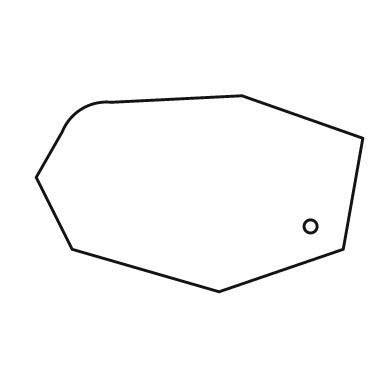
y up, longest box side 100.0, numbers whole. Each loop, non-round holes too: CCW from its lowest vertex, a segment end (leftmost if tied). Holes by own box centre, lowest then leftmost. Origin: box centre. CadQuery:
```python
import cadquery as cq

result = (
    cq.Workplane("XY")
    .moveTo(6.0, -30.0)
    .lineTo(44.0, -17.0)
    .lineTo(50.0, 17.0)
    .lineTo(13.0, 30.0)
    .lineTo(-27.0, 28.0)
    .threePointArc((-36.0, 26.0), (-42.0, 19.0))
    .lineTo(-50.0, 5.0)
    .lineTo(-39.0, -17.0)
    .close()
    .moveTo(34.0, -10.0)
    .circle(2.0)
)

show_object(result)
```